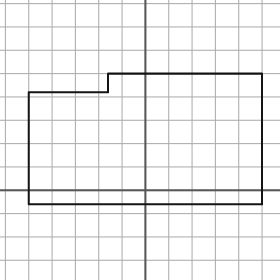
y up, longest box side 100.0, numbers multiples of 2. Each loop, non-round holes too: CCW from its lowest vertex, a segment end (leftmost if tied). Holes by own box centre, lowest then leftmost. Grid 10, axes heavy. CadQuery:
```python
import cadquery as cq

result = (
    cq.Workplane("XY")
    .moveTo(-50.0, -6.0)
    .lineTo(50.0, -6.0)
    .lineTo(50.0, 50.0)
    .lineTo(-16.0, 50.0)
    .lineTo(-16.0, 42.0)
    .lineTo(-50.0, 42.0)
    .close()
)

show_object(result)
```